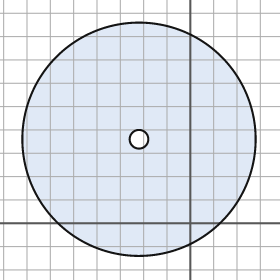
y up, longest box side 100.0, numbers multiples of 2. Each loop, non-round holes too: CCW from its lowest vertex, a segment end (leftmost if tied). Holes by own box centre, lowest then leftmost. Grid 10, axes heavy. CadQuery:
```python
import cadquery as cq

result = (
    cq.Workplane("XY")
    .moveTo(-22.0, 36.0)
    .circle(50.0)
    .moveTo(-22.0, 36.0)
    .circle(4.0)
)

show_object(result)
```